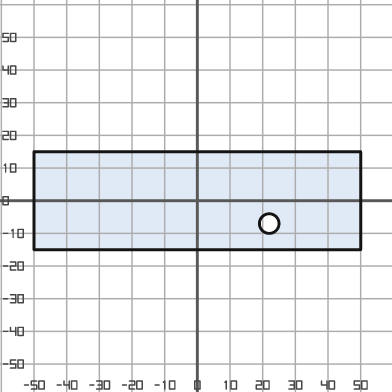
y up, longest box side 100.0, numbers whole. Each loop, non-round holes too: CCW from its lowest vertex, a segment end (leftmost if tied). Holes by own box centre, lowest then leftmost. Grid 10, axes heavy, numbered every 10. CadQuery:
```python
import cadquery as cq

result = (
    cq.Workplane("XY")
    .moveTo(-50.0, -15.0)
    .lineTo(50.0, -15.0)
    .lineTo(50.0, 15.0)
    .lineTo(-50.0, 15.0)
    .close()
    .moveTo(22.0, -7.0)
    .circle(3.0)
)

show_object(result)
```